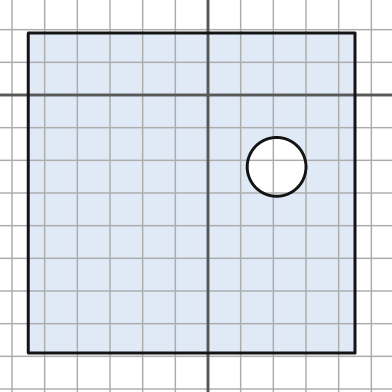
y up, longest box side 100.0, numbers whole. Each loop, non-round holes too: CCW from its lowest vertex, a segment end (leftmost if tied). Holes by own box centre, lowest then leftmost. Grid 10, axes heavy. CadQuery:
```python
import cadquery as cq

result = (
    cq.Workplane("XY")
    .moveTo(-55.0, -79.0)
    .lineTo(45.0, -79.0)
    .lineTo(45.0, 19.0)
    .lineTo(-55.0, 19.0)
    .close()
    .moveTo(21.0, -22.0)
    .circle(9.0)
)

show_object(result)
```